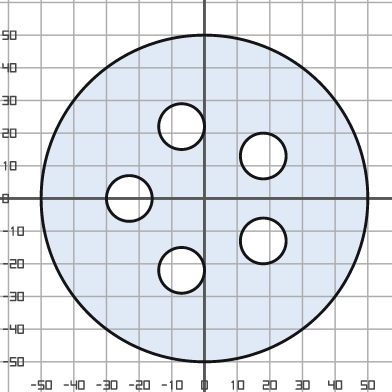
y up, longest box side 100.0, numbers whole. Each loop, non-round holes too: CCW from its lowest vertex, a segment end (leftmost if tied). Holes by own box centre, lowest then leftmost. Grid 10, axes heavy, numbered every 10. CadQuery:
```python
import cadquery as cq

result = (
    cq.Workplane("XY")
    .moveTo(0.0, 0.0)
    .circle(50.0)
    .moveTo(-7.0, -22.0)
    .circle(7.0)
    .moveTo(18.0, -13.0)
    .circle(7.0)
    .moveTo(-23.0, 0.0)
    .circle(7.0)
    .moveTo(18.0, 13.0)
    .circle(7.0)
    .moveTo(-7.0, 22.0)
    .circle(7.0)
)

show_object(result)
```